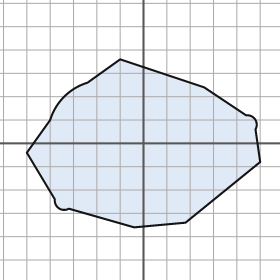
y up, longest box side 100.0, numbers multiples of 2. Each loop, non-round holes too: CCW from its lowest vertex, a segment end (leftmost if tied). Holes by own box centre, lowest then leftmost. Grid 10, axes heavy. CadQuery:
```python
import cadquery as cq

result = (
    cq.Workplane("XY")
    .moveTo(-4.0, -36.0)
    .lineTo(18.0, -34.0)
    .lineTo(50.0, -8.0)
    .lineTo(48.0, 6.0)
    .threePointArc((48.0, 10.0), (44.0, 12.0))
    .lineTo(26.0, 24.0)
    .lineTo(-10.0, 36.0)
    .lineTo(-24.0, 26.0)
    .threePointArc((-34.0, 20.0), (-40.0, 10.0))
    .lineTo(-50.0, -4.0)
    .lineTo(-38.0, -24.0)
    .threePointArc((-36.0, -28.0), (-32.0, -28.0))
    .close()
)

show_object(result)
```